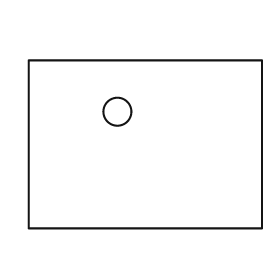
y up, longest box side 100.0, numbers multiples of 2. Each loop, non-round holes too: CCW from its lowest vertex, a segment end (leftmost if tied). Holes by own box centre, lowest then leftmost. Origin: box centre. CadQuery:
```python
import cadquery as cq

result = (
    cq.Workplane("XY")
    .moveTo(-50.0, -36.0)
    .lineTo(50.0, -36.0)
    .lineTo(50.0, 36.0)
    .lineTo(-50.0, 36.0)
    .close()
    .moveTo(-12.0, 14.0)
    .circle(6.0)
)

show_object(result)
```